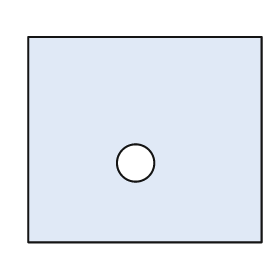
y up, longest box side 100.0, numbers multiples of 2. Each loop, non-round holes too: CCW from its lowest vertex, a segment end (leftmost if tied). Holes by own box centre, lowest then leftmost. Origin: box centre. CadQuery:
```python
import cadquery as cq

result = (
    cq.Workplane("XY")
    .moveTo(-50.0, -44.0)
    .lineTo(50.0, -44.0)
    .lineTo(50.0, 44.0)
    .lineTo(-50.0, 44.0)
    .close()
    .moveTo(-4.0, -10.0)
    .circle(8.0)
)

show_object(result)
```